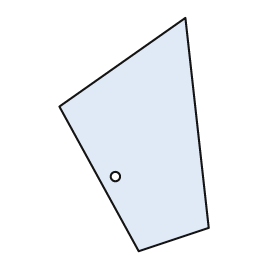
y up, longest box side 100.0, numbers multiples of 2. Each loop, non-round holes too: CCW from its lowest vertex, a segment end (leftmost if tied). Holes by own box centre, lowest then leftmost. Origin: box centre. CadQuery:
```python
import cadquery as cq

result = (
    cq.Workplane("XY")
    .moveTo(2.0, -50.0)
    .lineTo(32.0, -40.0)
    .lineTo(22.0, 50.0)
    .lineTo(-32.0, 12.0)
    .close()
    .moveTo(-8.0, -18.0)
    .circle(2.0)
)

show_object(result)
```